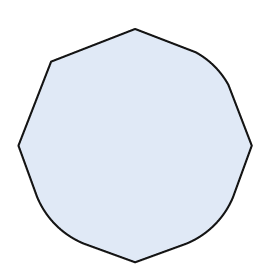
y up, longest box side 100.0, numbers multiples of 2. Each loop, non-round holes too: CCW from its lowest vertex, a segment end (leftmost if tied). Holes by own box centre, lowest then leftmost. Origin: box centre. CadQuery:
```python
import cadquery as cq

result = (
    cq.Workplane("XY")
    .moveTo(0.0, -50.0)
    .lineTo(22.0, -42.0)
    .threePointArc((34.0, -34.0), (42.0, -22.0))
    .lineTo(50.0, 0.0)
    .lineTo(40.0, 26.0)
    .threePointArc((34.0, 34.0), (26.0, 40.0))
    .lineTo(0.0, 50.0)
    .lineTo(-36.0, 36.0)
    .lineTo(-50.0, 0.0)
    .lineTo(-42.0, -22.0)
    .threePointArc((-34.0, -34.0), (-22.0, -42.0))
    .close()
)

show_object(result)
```